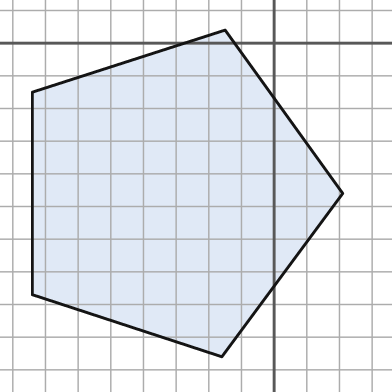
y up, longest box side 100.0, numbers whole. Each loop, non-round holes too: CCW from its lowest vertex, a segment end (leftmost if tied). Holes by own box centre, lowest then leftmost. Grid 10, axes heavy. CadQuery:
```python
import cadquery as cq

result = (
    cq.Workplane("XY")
    .moveTo(-16.0, -96.0)
    .lineTo(21.0, -46.0)
    .lineTo(-15.0, 4.0)
    .lineTo(-74.0, -15.0)
    .lineTo(-74.0, -77.0)
    .close()
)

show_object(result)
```